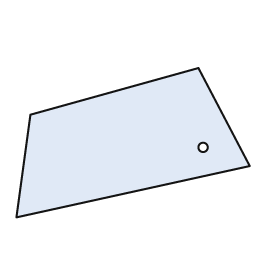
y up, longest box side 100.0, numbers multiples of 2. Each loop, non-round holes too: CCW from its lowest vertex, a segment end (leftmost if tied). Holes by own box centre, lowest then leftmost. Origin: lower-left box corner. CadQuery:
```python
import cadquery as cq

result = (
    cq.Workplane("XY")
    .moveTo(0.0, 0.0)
    .lineTo(100.0, 22.0)
    .lineTo(78.0, 64.0)
    .lineTo(6.0, 44.0)
    .close()
    .moveTo(80.0, 30.0)
    .circle(2.0)
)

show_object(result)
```